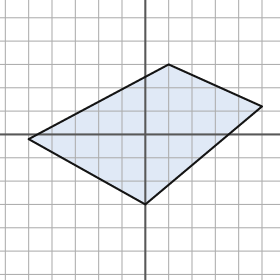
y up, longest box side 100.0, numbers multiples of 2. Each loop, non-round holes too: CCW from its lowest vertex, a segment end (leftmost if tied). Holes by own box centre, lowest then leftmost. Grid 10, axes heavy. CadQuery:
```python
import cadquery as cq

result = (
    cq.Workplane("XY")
    .moveTo(0.0, -30.0)
    .lineTo(50.0, 12.0)
    .lineTo(10.0, 30.0)
    .lineTo(-50.0, -2.0)
    .close()
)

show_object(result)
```